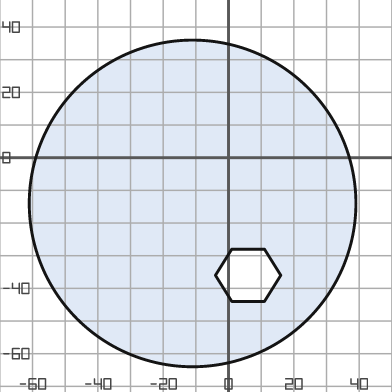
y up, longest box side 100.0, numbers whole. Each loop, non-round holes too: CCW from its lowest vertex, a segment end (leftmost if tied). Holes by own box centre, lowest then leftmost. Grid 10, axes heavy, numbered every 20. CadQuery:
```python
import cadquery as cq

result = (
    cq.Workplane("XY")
    .moveTo(-11.0, -14.0)
    .circle(50.0)
    .moveTo(1.0, -44.0)
    .lineTo(11.0, -44.0)
    .lineTo(16.0, -36.0)
    .lineTo(11.0, -28.0)
    .lineTo(1.0, -28.0)
    .lineTo(-4.0, -36.0)
    .close()
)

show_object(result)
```